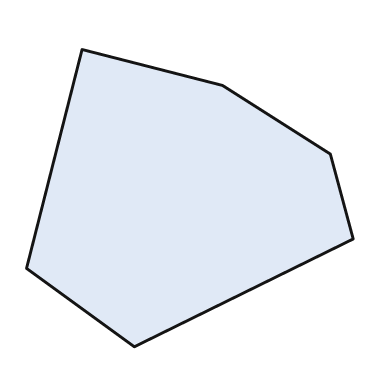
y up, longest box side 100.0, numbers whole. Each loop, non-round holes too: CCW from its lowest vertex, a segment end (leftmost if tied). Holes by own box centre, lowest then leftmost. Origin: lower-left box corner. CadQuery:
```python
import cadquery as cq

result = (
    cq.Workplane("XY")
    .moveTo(33.0, 0.0)
    .lineTo(100.0, 33.0)
    .lineTo(93.0, 59.0)
    .lineTo(60.0, 80.0)
    .lineTo(17.0, 91.0)
    .lineTo(0.0, 24.0)
    .close()
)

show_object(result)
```